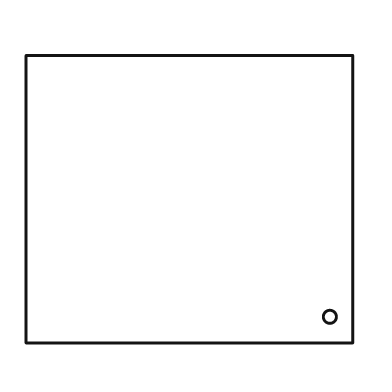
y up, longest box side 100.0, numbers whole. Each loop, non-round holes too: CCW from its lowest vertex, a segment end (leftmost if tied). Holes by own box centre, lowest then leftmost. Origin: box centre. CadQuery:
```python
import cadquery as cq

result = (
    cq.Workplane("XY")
    .moveTo(-50.0, -44.0)
    .lineTo(50.0, -44.0)
    .lineTo(50.0, 44.0)
    .lineTo(-50.0, 44.0)
    .close()
    .moveTo(43.0, -36.0)
    .circle(2.0)
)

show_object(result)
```